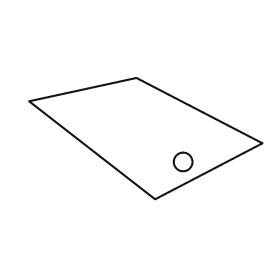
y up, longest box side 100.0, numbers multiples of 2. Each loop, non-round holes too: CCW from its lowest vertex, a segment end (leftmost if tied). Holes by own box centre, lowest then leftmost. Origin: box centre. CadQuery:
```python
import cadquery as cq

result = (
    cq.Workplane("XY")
    .moveTo(4.0, -26.0)
    .lineTo(50.0, -2.0)
    .lineTo(-4.0, 26.0)
    .lineTo(-50.0, 16.0)
    .close()
    .moveTo(16.0, -10.0)
    .circle(4.0)
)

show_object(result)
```